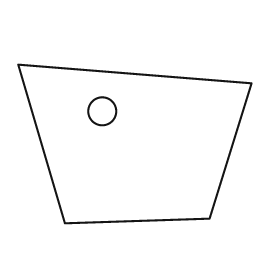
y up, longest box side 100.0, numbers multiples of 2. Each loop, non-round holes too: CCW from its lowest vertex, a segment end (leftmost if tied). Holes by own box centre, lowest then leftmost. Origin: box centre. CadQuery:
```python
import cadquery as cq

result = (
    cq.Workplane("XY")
    .moveTo(-30.0, -34.0)
    .lineTo(32.0, -32.0)
    .lineTo(50.0, 26.0)
    .lineTo(-50.0, 34.0)
    .close()
    .moveTo(-14.0, 14.0)
    .circle(6.0)
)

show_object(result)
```